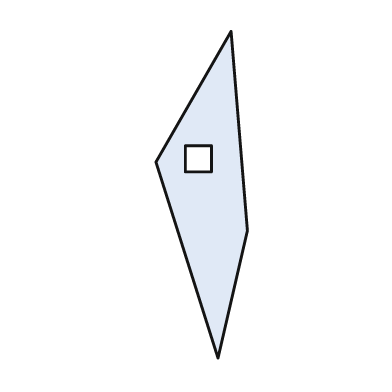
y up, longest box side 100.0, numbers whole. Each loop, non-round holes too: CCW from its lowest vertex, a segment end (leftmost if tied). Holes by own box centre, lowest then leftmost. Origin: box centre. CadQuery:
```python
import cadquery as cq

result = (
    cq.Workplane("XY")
    .moveTo(5.0, -50.0)
    .lineTo(14.0, -11.0)
    .lineTo(9.0, 50.0)
    .lineTo(-14.0, 10.0)
    .close()
    .moveTo(-5.0, 7.0)
    .lineTo(3.0, 7.0)
    .lineTo(3.0, 15.0)
    .lineTo(-5.0, 15.0)
    .close()
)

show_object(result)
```